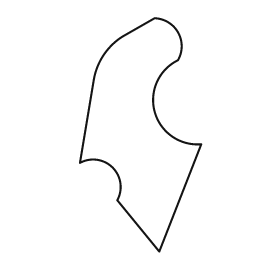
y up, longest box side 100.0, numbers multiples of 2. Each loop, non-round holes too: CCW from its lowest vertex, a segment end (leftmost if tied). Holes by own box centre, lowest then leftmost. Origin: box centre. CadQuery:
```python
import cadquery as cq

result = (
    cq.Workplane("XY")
    .moveTo(8.0, -50.0)
    .lineTo(26.0, -4.0)
    .threePointArc((6.0, 10.0), (16.0, 32.0))
    .threePointArc((16.0, 44.0), (6.0, 50.0))
    .lineTo(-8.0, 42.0)
    .threePointArc((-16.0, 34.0), (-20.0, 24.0))
    .lineTo(-26.0, -12.0)
    .threePointArc((-12.0, -14.0), (-10.0, -28.0))
    .close()
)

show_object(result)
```